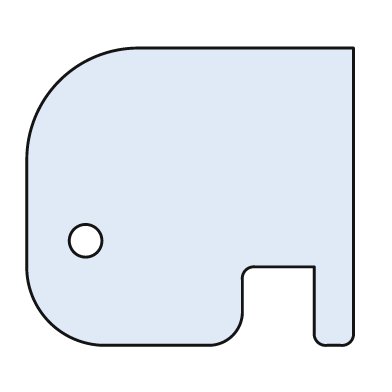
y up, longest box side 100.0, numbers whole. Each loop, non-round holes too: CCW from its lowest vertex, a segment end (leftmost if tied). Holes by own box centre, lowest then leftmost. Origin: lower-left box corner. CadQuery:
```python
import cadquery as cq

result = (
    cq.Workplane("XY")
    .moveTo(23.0, 0.0)
    .lineTo(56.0, 0.0)
    .threePointArc((63.0, 3.0), (66.0, 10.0))
    .lineTo(66.0, 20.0)
    .threePointArc((67.0, 23.0), (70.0, 24.0))
    .lineTo(88.0, 24.0)
    .lineTo(88.0, 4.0)
    .threePointArc((89.0, 1.0), (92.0, 0.0))
    .lineTo(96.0, 0.0)
    .threePointArc((99.0, 1.0), (100.0, 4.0))
    .lineTo(100.0, 91.0)
    .lineTo(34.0, 91.0)
    .threePointArc((10.0, 81.0), (0.0, 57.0))
    .lineTo(0.0, 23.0)
    .threePointArc((7.0, 7.0), (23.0, 0.0))
    .close()
    .moveTo(18.0, 32.0)
    .circle(5.0)
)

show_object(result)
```